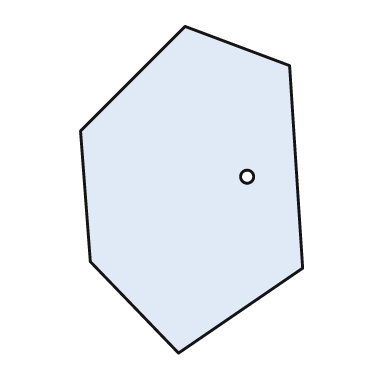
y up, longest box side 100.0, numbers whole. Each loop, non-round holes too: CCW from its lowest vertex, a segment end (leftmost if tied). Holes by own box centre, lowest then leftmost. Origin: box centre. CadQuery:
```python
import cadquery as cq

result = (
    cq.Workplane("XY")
    .moveTo(-4.0, -50.0)
    .lineTo(34.0, -24.0)
    .lineTo(30.0, 38.0)
    .lineTo(-2.0, 50.0)
    .lineTo(-34.0, 18.0)
    .lineTo(-31.0, -22.0)
    .close()
    .moveTo(17.0, 4.0)
    .circle(2.0)
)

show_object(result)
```